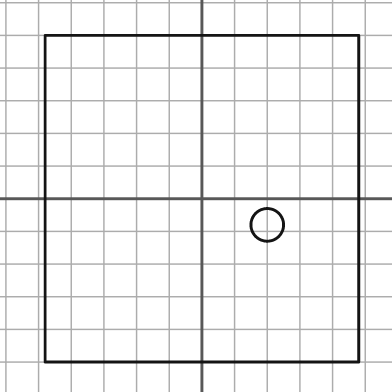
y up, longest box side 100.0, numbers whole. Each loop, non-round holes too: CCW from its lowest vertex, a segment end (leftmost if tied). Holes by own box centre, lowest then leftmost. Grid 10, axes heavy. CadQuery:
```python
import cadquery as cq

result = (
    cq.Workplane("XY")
    .moveTo(-48.0, -50.0)
    .lineTo(48.0, -50.0)
    .lineTo(48.0, 50.0)
    .lineTo(-48.0, 50.0)
    .close()
    .moveTo(20.0, -8.0)
    .circle(5.0)
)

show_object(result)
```